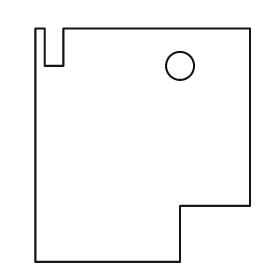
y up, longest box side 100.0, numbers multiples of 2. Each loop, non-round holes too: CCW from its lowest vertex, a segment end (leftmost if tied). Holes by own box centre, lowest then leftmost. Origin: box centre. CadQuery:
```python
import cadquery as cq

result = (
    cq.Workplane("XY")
    .moveTo(-46.0, -50.0)
    .lineTo(16.0, -50.0)
    .lineTo(16.0, -26.0)
    .lineTo(46.0, -26.0)
    .lineTo(46.0, 50.0)
    .lineTo(-34.0, 50.0)
    .lineTo(-34.0, 34.0)
    .lineTo(-42.0, 34.0)
    .lineTo(-42.0, 50.0)
    .lineTo(-46.0, 50.0)
    .close()
    .moveTo(16.0, 34.0)
    .circle(6.0)
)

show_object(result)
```